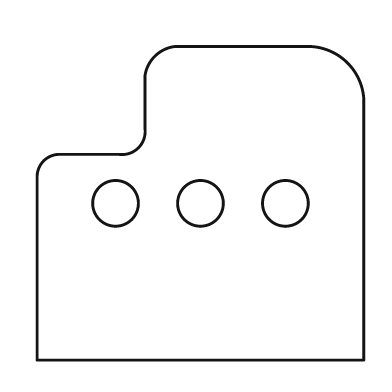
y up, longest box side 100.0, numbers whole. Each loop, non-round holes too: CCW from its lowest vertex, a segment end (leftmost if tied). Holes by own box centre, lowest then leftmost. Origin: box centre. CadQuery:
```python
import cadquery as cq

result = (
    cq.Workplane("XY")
    .moveTo(-50.0, -48.0)
    .lineTo(50.0, -48.0)
    .lineTo(50.0, 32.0)
    .threePointArc((45.0, 43.0), (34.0, 48.0))
    .lineTo(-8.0, 48.0)
    .threePointArc((-14.0, 45.0), (-17.0, 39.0))
    .lineTo(-17.0, 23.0)
    .threePointArc((-19.0, 17.0), (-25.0, 15.0))
    .lineTo(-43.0, 15.0)
    .threePointArc((-48.0, 13.0), (-50.0, 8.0))
    .close()
    .moveTo(-26.0, 0.0)
    .circle(7.0)
    .moveTo(0.0, 0.0)
    .circle(7.0)
    .moveTo(26.0, 0.0)
    .circle(7.0)
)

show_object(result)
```